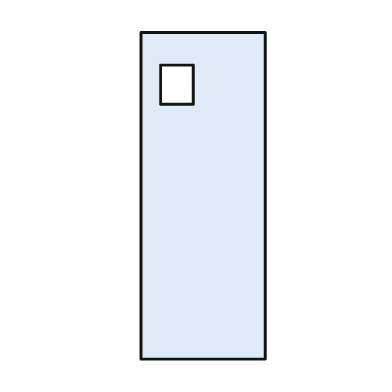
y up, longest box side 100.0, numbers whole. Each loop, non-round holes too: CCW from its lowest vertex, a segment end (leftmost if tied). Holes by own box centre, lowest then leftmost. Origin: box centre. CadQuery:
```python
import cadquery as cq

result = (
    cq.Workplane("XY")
    .moveTo(-19.0, -50.0)
    .lineTo(19.0, -50.0)
    .lineTo(19.0, 50.0)
    .lineTo(-19.0, 50.0)
    .close()
    .moveTo(-13.0, 28.0)
    .lineTo(-3.0, 28.0)
    .lineTo(-3.0, 40.0)
    .lineTo(-13.0, 40.0)
    .close()
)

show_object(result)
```